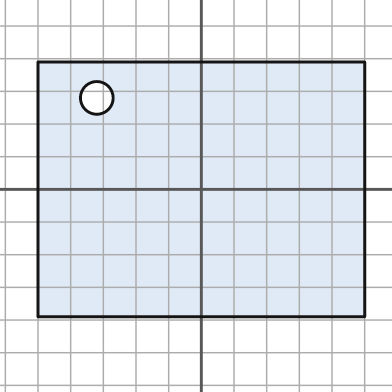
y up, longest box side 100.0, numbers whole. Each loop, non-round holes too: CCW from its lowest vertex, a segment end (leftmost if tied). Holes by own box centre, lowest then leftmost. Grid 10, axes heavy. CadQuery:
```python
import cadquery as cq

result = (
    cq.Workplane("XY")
    .moveTo(-50.0, -39.0)
    .lineTo(50.0, -39.0)
    .lineTo(50.0, 39.0)
    .lineTo(-50.0, 39.0)
    .close()
    .moveTo(-32.0, 28.0)
    .circle(5.0)
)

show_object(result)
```